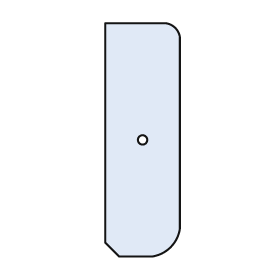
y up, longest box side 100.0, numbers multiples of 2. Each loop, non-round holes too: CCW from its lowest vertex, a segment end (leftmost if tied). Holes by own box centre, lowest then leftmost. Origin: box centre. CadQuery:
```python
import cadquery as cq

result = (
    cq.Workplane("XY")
    .moveTo(-10.0, -50.0)
    .lineTo(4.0, -50.0)
    .threePointArc((12.0, -46.0), (16.0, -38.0))
    .lineTo(16.0, 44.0)
    .threePointArc((14.0, 48.0), (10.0, 50.0))
    .lineTo(-16.0, 50.0)
    .lineTo(-16.0, -44.0)
    .close()
    .moveTo(0.0, 0.0)
    .circle(2.0)
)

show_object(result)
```